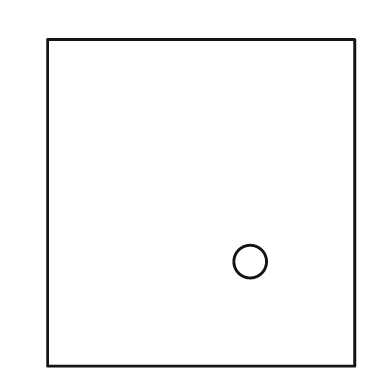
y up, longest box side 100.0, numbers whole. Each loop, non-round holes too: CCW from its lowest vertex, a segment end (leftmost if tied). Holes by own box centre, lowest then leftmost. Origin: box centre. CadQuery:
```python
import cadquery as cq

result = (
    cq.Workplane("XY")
    .moveTo(-47.0, -50.0)
    .lineTo(47.0, -50.0)
    .lineTo(47.0, 50.0)
    .lineTo(-47.0, 50.0)
    .close()
    .moveTo(15.0, -18.0)
    .circle(5.0)
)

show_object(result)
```